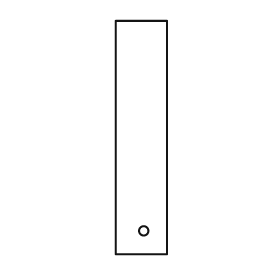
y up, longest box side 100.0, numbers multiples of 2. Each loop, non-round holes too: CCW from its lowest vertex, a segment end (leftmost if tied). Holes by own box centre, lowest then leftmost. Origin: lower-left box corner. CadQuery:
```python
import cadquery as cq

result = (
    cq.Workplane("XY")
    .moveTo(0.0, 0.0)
    .lineTo(22.0, 0.0)
    .lineTo(22.0, 100.0)
    .lineTo(0.0, 100.0)
    .close()
    .moveTo(12.0, 10.0)
    .circle(2.0)
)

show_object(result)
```